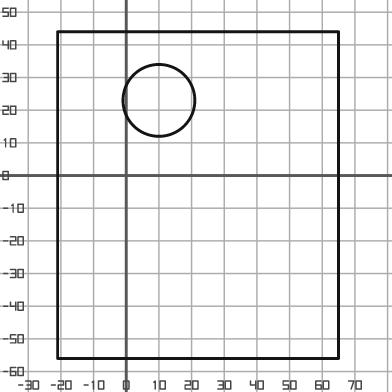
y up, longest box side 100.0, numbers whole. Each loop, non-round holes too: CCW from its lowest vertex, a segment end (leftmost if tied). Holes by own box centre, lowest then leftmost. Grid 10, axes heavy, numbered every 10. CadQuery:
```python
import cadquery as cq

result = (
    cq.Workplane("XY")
    .moveTo(-21.0, -56.0)
    .lineTo(65.0, -56.0)
    .lineTo(65.0, 44.0)
    .lineTo(-21.0, 44.0)
    .close()
    .moveTo(10.0, 23.0)
    .circle(11.0)
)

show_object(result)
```